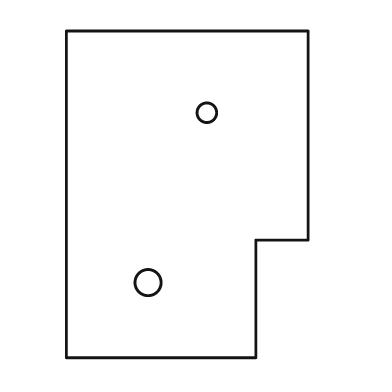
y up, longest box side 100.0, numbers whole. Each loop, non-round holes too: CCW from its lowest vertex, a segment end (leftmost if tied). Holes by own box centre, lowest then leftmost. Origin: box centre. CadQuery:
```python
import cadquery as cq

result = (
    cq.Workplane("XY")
    .moveTo(-37.0, -50.0)
    .lineTo(21.0, -50.0)
    .lineTo(21.0, -14.0)
    .lineTo(37.0, -14.0)
    .lineTo(37.0, 50.0)
    .lineTo(-37.0, 50.0)
    .close()
    .moveTo(-12.0, -27.0)
    .circle(4.0)
    .moveTo(6.0, 25.0)
    .circle(3.0)
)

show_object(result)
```